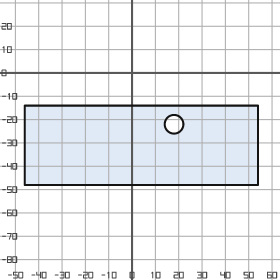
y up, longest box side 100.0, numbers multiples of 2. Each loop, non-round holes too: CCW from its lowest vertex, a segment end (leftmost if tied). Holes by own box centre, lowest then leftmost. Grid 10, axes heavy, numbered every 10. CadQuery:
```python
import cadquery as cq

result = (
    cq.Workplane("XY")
    .moveTo(-46.0, -48.0)
    .lineTo(54.0, -48.0)
    .lineTo(54.0, -14.0)
    .lineTo(-46.0, -14.0)
    .close()
    .moveTo(18.0, -22.0)
    .circle(4.0)
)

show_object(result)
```